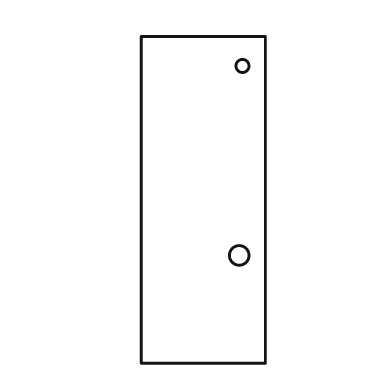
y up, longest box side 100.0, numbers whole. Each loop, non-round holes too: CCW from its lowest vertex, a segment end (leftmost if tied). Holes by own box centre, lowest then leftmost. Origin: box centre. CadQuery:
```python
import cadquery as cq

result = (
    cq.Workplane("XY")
    .moveTo(-19.0, -50.0)
    .lineTo(19.0, -50.0)
    .lineTo(19.0, 50.0)
    .lineTo(-19.0, 50.0)
    .close()
    .moveTo(11.0, -17.0)
    .circle(3.0)
    .moveTo(12.0, 41.0)
    .circle(2.0)
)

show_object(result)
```